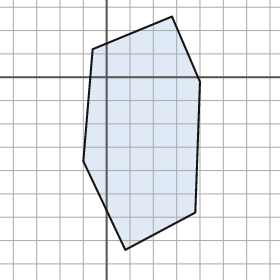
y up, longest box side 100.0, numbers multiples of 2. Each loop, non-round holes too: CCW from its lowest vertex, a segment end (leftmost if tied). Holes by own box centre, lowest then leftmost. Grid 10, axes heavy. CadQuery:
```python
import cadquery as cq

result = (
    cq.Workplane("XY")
    .moveTo(8.0, -74.0)
    .lineTo(38.0, -58.0)
    .lineTo(40.0, -2.0)
    .lineTo(28.0, 26.0)
    .lineTo(-6.0, 12.0)
    .lineTo(-10.0, -36.0)
    .close()
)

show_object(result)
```